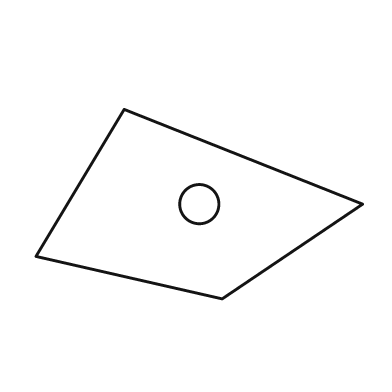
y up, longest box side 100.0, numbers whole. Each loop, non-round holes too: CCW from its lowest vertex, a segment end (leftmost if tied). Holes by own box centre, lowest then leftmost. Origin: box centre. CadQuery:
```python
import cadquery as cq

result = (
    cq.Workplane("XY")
    .moveTo(7.0, -29.0)
    .lineTo(50.0, 0.0)
    .lineTo(-23.0, 29.0)
    .lineTo(-50.0, -16.0)
    .close()
    .moveTo(0.0, 0.0)
    .circle(6.0)
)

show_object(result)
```